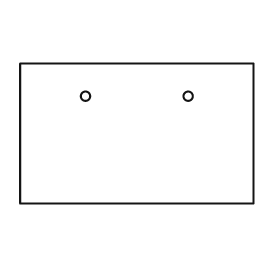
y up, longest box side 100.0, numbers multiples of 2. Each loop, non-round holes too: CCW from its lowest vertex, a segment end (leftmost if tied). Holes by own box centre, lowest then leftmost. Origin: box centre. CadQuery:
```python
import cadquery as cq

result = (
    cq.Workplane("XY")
    .moveTo(-50.0, -30.0)
    .lineTo(50.0, -30.0)
    .lineTo(50.0, 30.0)
    .lineTo(-50.0, 30.0)
    .close()
    .moveTo(-22.0, 16.0)
    .circle(2.0)
    .moveTo(22.0, 16.0)
    .circle(2.0)
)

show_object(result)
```